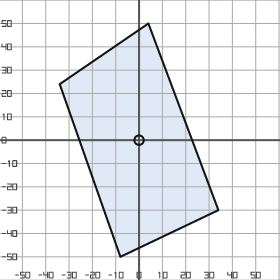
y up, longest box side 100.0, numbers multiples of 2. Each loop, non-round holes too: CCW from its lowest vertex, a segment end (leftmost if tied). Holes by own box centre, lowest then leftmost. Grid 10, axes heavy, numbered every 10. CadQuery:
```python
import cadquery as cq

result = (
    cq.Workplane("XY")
    .moveTo(-8.0, -50.0)
    .lineTo(34.0, -30.0)
    .lineTo(4.0, 50.0)
    .lineTo(-34.0, 24.0)
    .close()
    .moveTo(0.0, 0.0)
    .circle(2.0)
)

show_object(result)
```